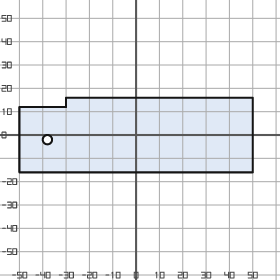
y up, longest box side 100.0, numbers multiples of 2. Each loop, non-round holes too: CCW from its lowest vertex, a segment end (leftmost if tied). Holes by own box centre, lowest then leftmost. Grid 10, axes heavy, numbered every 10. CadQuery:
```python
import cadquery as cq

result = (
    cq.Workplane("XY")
    .moveTo(-50.0, -16.0)
    .lineTo(50.0, -16.0)
    .lineTo(50.0, 16.0)
    .lineTo(-30.0, 16.0)
    .lineTo(-30.0, 12.0)
    .lineTo(-50.0, 12.0)
    .close()
    .moveTo(-38.0, -2.0)
    .circle(2.0)
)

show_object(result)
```